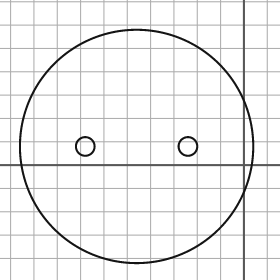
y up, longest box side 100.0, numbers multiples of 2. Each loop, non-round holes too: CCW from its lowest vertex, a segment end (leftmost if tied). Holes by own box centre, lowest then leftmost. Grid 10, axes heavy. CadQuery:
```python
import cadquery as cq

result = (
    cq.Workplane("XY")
    .moveTo(-46.0, 8.0)
    .circle(50.0)
    .moveTo(-68.0, 8.0)
    .circle(4.0)
    .moveTo(-24.0, 8.0)
    .circle(4.0)
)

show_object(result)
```